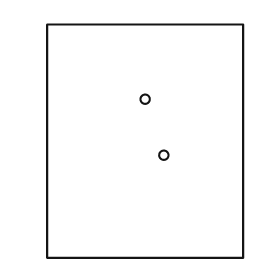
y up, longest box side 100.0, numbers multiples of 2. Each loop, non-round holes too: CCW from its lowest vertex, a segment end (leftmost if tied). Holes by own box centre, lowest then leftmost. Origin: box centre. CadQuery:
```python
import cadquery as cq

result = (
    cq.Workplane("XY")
    .moveTo(-42.0, -50.0)
    .lineTo(42.0, -50.0)
    .lineTo(42.0, 50.0)
    .lineTo(-42.0, 50.0)
    .close()
    .moveTo(8.0, -6.0)
    .circle(2.0)
    .moveTo(0.0, 18.0)
    .circle(2.0)
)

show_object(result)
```